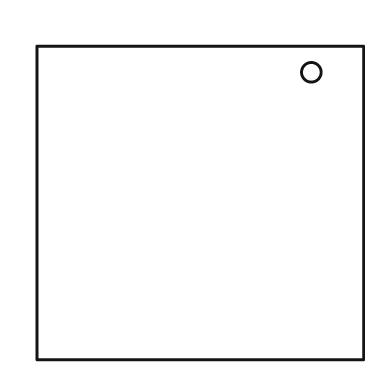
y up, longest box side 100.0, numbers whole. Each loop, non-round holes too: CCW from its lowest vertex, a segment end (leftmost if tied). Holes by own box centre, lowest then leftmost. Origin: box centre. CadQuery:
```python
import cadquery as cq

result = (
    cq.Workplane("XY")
    .moveTo(-50.0, -48.0)
    .lineTo(50.0, -48.0)
    .lineTo(50.0, 48.0)
    .lineTo(-50.0, 48.0)
    .close()
    .moveTo(34.0, 40.0)
    .circle(3.0)
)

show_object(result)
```